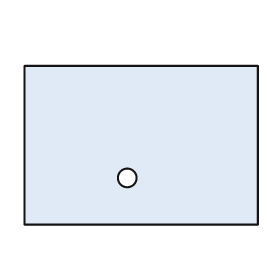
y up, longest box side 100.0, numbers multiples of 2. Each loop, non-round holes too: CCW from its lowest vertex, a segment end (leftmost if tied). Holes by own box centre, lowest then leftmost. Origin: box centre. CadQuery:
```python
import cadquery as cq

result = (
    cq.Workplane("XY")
    .moveTo(-50.0, -34.0)
    .lineTo(50.0, -34.0)
    .lineTo(50.0, 34.0)
    .lineTo(-50.0, 34.0)
    .close()
    .moveTo(-6.0, -14.0)
    .circle(4.0)
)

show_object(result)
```